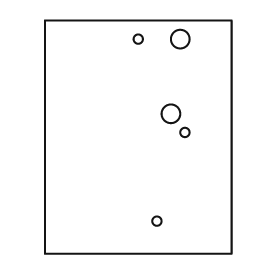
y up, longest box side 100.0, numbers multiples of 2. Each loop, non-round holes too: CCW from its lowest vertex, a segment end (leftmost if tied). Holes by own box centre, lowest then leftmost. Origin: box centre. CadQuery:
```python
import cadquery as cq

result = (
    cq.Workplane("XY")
    .moveTo(-40.0, -50.0)
    .lineTo(40.0, -50.0)
    .lineTo(40.0, 50.0)
    .lineTo(-40.0, 50.0)
    .close()
    .moveTo(8.0, -36.0)
    .circle(2.0)
    .moveTo(20.0, 2.0)
    .circle(2.0)
    .moveTo(14.0, 10.0)
    .circle(4.0)
    .moveTo(0.0, 42.0)
    .circle(2.0)
    .moveTo(18.0, 42.0)
    .circle(4.0)
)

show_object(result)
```